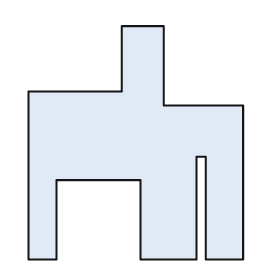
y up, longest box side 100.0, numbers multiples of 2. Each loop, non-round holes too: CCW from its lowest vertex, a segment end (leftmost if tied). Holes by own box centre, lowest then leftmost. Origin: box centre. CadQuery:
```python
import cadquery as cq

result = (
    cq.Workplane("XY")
    .moveTo(-46.0, -50.0)
    .lineTo(-34.0, -50.0)
    .lineTo(-34.0, -16.0)
    .lineTo(2.0, -16.0)
    .lineTo(2.0, -50.0)
    .lineTo(26.0, -50.0)
    .lineTo(26.0, -6.0)
    .lineTo(30.0, -6.0)
    .lineTo(30.0, -50.0)
    .lineTo(46.0, -50.0)
    .lineTo(46.0, 16.0)
    .lineTo(12.0, 16.0)
    .lineTo(12.0, 50.0)
    .lineTo(-6.0, 50.0)
    .lineTo(-6.0, 22.0)
    .lineTo(-46.0, 22.0)
    .close()
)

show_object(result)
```